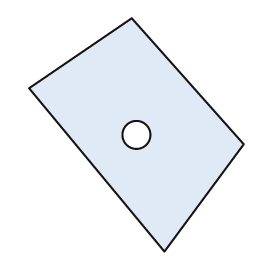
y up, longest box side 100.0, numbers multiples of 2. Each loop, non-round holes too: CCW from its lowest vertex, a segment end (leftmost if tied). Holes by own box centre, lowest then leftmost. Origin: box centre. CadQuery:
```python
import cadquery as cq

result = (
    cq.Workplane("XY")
    .moveTo(12.0, -50.0)
    .lineTo(46.0, -4.0)
    .lineTo(-2.0, 50.0)
    .lineTo(-46.0, 20.0)
    .close()
    .moveTo(0.0, 0.0)
    .circle(6.0)
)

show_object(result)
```